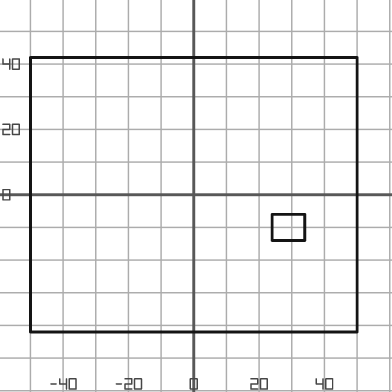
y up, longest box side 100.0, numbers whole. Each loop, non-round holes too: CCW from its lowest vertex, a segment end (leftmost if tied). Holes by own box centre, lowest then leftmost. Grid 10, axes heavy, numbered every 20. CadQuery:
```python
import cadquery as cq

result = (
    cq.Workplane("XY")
    .moveTo(-50.0, -42.0)
    .lineTo(50.0, -42.0)
    .lineTo(50.0, 42.0)
    .lineTo(-50.0, 42.0)
    .close()
    .moveTo(24.0, -14.0)
    .lineTo(34.0, -14.0)
    .lineTo(34.0, -6.0)
    .lineTo(24.0, -6.0)
    .close()
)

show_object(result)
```